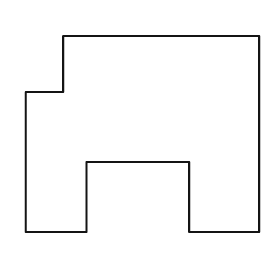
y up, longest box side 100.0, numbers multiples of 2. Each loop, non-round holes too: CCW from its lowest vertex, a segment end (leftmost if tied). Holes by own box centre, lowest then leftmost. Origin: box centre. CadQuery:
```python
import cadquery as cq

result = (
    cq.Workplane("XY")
    .moveTo(-50.0, -42.0)
    .lineTo(-24.0, -42.0)
    .lineTo(-24.0, -12.0)
    .lineTo(20.0, -12.0)
    .lineTo(20.0, -42.0)
    .lineTo(50.0, -42.0)
    .lineTo(50.0, 42.0)
    .lineTo(-34.0, 42.0)
    .lineTo(-34.0, 18.0)
    .lineTo(-50.0, 18.0)
    .close()
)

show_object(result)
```